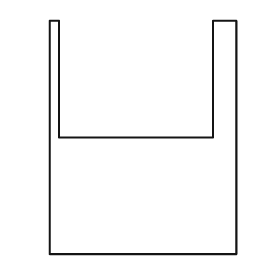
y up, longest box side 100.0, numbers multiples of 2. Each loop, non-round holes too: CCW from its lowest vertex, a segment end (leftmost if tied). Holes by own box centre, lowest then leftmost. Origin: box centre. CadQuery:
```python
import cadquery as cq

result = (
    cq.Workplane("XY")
    .moveTo(-40.0, -50.0)
    .lineTo(40.0, -50.0)
    .lineTo(40.0, 50.0)
    .lineTo(30.0, 50.0)
    .lineTo(30.0, 0.0)
    .lineTo(-36.0, 0.0)
    .lineTo(-36.0, 50.0)
    .lineTo(-40.0, 50.0)
    .close()
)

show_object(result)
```